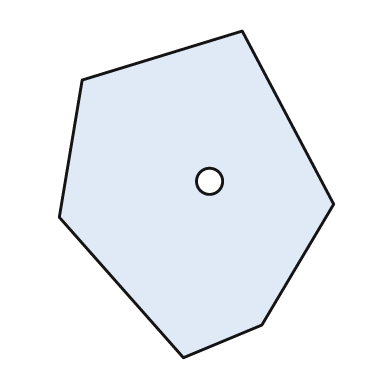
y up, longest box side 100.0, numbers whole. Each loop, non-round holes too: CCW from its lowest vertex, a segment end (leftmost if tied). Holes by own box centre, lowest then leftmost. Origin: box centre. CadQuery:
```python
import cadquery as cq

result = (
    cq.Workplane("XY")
    .moveTo(-4.0, -50.0)
    .lineTo(20.0, -40.0)
    .lineTo(42.0, -3.0)
    .lineTo(14.0, 50.0)
    .lineTo(-35.0, 35.0)
    .lineTo(-42.0, -7.0)
    .close()
    .moveTo(4.0, 4.0)
    .circle(4.0)
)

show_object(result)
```